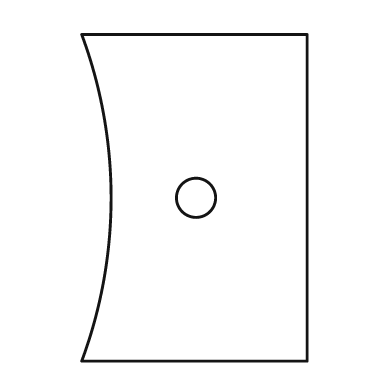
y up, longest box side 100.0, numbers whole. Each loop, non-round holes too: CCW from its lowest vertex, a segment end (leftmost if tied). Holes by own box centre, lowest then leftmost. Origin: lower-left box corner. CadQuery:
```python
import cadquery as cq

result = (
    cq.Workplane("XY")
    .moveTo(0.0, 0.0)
    .lineTo(69.0, 0.0)
    .lineTo(69.0, 100.0)
    .lineTo(0.0, 100.0)
    .threePointArc((9.0, 50.0), (0.0, 0.0))
    .close()
    .moveTo(35.0, 50.0)
    .circle(6.0)
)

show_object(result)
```